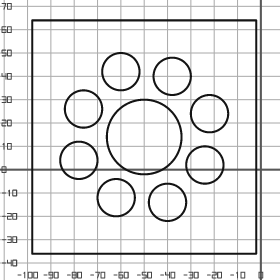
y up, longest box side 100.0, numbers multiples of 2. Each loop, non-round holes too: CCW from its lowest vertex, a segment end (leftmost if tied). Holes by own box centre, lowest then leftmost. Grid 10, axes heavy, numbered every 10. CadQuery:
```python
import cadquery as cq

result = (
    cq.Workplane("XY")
    .moveTo(-98.0, -36.0)
    .lineTo(-2.0, -36.0)
    .lineTo(-2.0, 64.0)
    .lineTo(-98.0, 64.0)
    .close()
    .moveTo(-40.0, -14.0)
    .circle(8.0)
    .moveTo(-62.0, -12.0)
    .circle(8.0)
    .moveTo(-24.0, 2.0)
    .circle(8.0)
    .moveTo(-78.0, 4.0)
    .circle(8.0)
    .moveTo(-50.0, 14.0)
    .circle(16.0)
    .moveTo(-22.0, 24.0)
    .circle(8.0)
    .moveTo(-76.0, 26.0)
    .circle(8.0)
    .moveTo(-38.0, 40.0)
    .circle(8.0)
    .moveTo(-60.0, 42.0)
    .circle(8.0)
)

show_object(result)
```